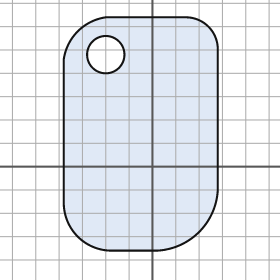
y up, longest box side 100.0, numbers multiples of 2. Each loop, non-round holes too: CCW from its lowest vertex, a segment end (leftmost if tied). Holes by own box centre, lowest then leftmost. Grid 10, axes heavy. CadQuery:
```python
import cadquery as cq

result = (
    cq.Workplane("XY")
    .moveTo(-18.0, -36.0)
    .lineTo(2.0, -36.0)
    .threePointArc((20.0, -28.0), (28.0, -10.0))
    .lineTo(28.0, 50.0)
    .threePointArc((24.0, 60.0), (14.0, 64.0))
    .lineTo(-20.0, 64.0)
    .threePointArc((-32.0, 58.0), (-38.0, 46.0))
    .lineTo(-38.0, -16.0)
    .threePointArc((-32.0, -30.0), (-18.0, -36.0))
    .close()
    .moveTo(-20.0, 48.0)
    .circle(8.0)
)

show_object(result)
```